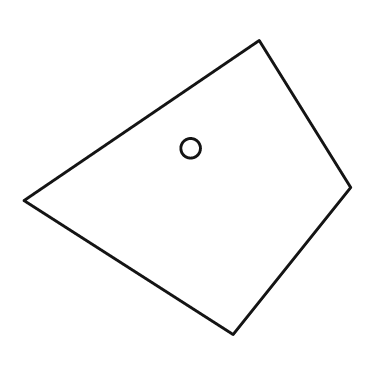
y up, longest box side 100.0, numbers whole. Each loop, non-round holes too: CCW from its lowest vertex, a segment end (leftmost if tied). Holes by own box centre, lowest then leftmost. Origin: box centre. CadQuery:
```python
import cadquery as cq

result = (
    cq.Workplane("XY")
    .moveTo(14.0, -45.0)
    .lineTo(50.0, 0.0)
    .lineTo(22.0, 45.0)
    .lineTo(-50.0, -4.0)
    .close()
    .moveTo(1.0, 12.0)
    .circle(3.0)
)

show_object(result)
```